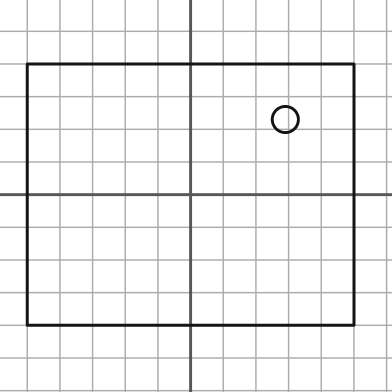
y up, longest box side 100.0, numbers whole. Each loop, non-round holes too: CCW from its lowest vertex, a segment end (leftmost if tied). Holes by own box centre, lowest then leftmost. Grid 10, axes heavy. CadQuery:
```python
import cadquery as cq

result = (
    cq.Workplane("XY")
    .moveTo(-50.0, -40.0)
    .lineTo(50.0, -40.0)
    .lineTo(50.0, 40.0)
    .lineTo(-50.0, 40.0)
    .close()
    .moveTo(29.0, 23.0)
    .circle(4.0)
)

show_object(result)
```